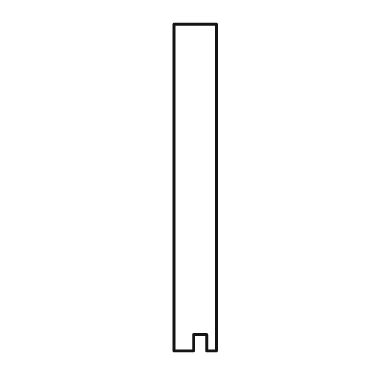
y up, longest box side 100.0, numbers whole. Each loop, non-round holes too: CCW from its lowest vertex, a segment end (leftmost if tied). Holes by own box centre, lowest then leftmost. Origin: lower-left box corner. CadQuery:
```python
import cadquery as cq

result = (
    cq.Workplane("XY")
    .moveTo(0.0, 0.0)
    .lineTo(6.0, 0.0)
    .lineTo(6.0, 5.0)
    .lineTo(10.0, 5.0)
    .lineTo(10.0, 0.0)
    .lineTo(13.0, 0.0)
    .lineTo(13.0, 100.0)
    .lineTo(0.0, 100.0)
    .close()
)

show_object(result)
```